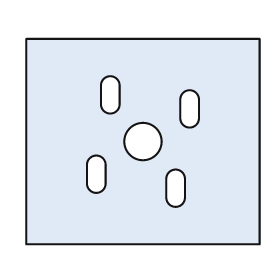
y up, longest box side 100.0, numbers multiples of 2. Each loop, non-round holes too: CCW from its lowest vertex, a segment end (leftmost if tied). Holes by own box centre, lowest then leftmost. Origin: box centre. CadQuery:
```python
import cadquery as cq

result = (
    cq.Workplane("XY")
    .moveTo(-50.0, -44.0)
    .lineTo(50.0, -44.0)
    .lineTo(50.0, 44.0)
    .lineTo(-50.0, 44.0)
    .close()
    .moveTo(10.0, -24.0)
    .threePointArc((14.0, -28.0), (18.0, -24.0))
    .lineTo(18.0, -16.0)
    .threePointArc((14.0, -12.0), (10.0, -16.0))
    .close()
    .moveTo(-24.0, -18.0)
    .threePointArc((-20.0, -22.0), (-16.0, -18.0))
    .lineTo(-16.0, -10.0)
    .threePointArc((-20.0, -6.0), (-24.0, -10.0))
    .close()
    .moveTo(0.0, 0.0)
    .circle(8.0)
    .moveTo(16.0, 10.0)
    .threePointArc((20.0, 6.0), (24.0, 10.0))
    .lineTo(24.0, 18.0)
    .threePointArc((20.0, 22.0), (16.0, 18.0))
    .close()
    .moveTo(-18.0, 16.0)
    .threePointArc((-14.0, 12.0), (-10.0, 16.0))
    .lineTo(-10.0, 24.0)
    .threePointArc((-14.0, 28.0), (-18.0, 24.0))
    .close()
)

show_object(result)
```